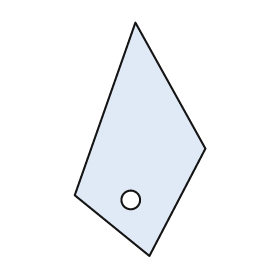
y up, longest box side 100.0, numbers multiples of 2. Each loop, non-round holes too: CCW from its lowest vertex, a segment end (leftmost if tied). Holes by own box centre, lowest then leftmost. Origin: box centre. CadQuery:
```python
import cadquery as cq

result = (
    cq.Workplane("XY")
    .moveTo(4.0, -50.0)
    .lineTo(28.0, -4.0)
    .lineTo(-2.0, 50.0)
    .lineTo(-28.0, -24.0)
    .close()
    .moveTo(-4.0, -26.0)
    .circle(4.0)
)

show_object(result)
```